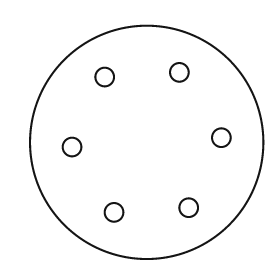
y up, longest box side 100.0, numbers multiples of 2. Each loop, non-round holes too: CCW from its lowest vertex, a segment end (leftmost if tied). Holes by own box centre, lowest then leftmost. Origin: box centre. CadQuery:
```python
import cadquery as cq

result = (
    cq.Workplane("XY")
    .moveTo(0.0, 0.0)
    .circle(50.0)
    .moveTo(-14.0, -30.0)
    .circle(4.0)
    .moveTo(18.0, -28.0)
    .circle(4.0)
    .moveTo(-32.0, -2.0)
    .circle(4.0)
    .moveTo(32.0, 2.0)
    .circle(4.0)
    .moveTo(-18.0, 28.0)
    .circle(4.0)
    .moveTo(14.0, 30.0)
    .circle(4.0)
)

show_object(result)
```